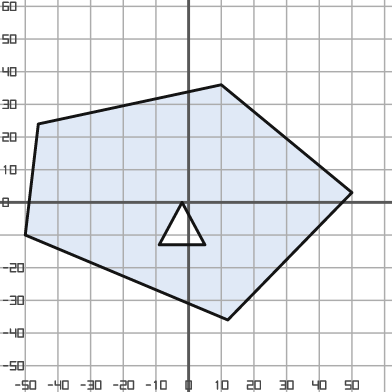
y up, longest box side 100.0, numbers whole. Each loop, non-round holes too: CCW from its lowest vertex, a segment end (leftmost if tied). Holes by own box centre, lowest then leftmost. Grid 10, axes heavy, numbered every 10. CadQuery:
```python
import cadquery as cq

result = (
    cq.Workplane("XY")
    .moveTo(12.0, -36.0)
    .lineTo(50.0, 3.0)
    .lineTo(10.0, 36.0)
    .lineTo(-46.0, 24.0)
    .lineTo(-50.0, -10.0)
    .close()
    .moveTo(-9.0, -13.0)
    .lineTo(5.0, -13.0)
    .lineTo(-2.0, 0.0)
    .close()
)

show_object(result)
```